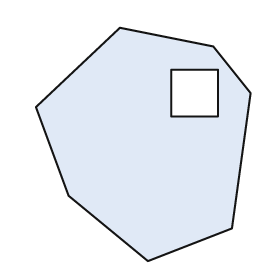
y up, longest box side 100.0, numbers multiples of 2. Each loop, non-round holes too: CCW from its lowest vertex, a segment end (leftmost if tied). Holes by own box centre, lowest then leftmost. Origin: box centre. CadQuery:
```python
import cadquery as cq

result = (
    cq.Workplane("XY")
    .moveTo(2.0, -50.0)
    .lineTo(38.0, -36.0)
    .lineTo(46.0, 22.0)
    .lineTo(30.0, 42.0)
    .lineTo(-10.0, 50.0)
    .lineTo(-46.0, 16.0)
    .lineTo(-32.0, -22.0)
    .close()
    .moveTo(12.0, 12.0)
    .lineTo(32.0, 12.0)
    .lineTo(32.0, 32.0)
    .lineTo(12.0, 32.0)
    .close()
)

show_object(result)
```